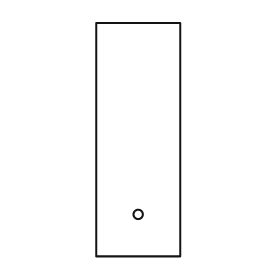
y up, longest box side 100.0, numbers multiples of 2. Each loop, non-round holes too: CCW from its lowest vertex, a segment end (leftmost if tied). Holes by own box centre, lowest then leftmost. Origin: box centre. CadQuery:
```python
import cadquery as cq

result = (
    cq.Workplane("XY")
    .moveTo(-18.0, -50.0)
    .lineTo(18.0, -50.0)
    .lineTo(18.0, 50.0)
    .lineTo(-18.0, 50.0)
    .close()
    .moveTo(0.0, -32.0)
    .circle(2.0)
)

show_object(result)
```